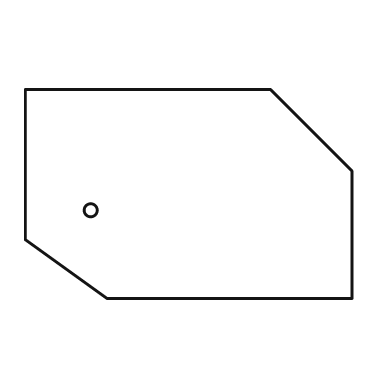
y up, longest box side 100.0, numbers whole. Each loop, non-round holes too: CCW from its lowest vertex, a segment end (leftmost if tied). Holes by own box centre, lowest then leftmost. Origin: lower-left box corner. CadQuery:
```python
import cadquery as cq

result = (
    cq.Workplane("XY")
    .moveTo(25.0, 0.0)
    .lineTo(100.0, 0.0)
    .lineTo(100.0, 39.0)
    .lineTo(75.0, 64.0)
    .lineTo(0.0, 64.0)
    .lineTo(0.0, 18.0)
    .close()
    .moveTo(20.0, 27.0)
    .circle(2.0)
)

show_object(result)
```